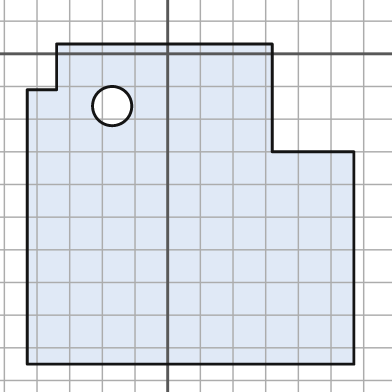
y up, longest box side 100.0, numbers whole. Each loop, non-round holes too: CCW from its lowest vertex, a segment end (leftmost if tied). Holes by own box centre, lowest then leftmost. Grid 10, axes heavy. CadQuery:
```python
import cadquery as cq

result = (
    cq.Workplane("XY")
    .moveTo(-43.0, -95.0)
    .lineTo(57.0, -95.0)
    .lineTo(57.0, -30.0)
    .lineTo(32.0, -30.0)
    .lineTo(32.0, 3.0)
    .lineTo(-34.0, 3.0)
    .lineTo(-34.0, -11.0)
    .lineTo(-43.0, -11.0)
    .close()
    .moveTo(-17.0, -16.0)
    .circle(6.0)
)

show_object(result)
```